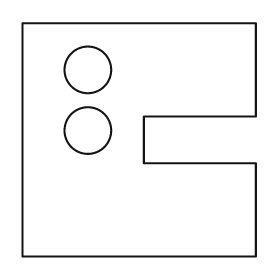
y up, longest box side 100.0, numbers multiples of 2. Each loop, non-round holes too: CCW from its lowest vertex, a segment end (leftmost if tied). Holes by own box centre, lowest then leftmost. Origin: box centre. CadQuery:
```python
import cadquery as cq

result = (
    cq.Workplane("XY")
    .moveTo(-50.0, -50.0)
    .lineTo(50.0, -50.0)
    .lineTo(50.0, -10.0)
    .lineTo(2.0, -10.0)
    .lineTo(2.0, 10.0)
    .lineTo(50.0, 10.0)
    .lineTo(50.0, 50.0)
    .lineTo(-50.0, 50.0)
    .close()
    .moveTo(-22.0, 4.0)
    .circle(10.0)
    .moveTo(-22.0, 30.0)
    .circle(10.0)
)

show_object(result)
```